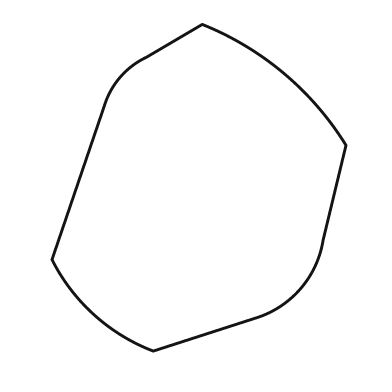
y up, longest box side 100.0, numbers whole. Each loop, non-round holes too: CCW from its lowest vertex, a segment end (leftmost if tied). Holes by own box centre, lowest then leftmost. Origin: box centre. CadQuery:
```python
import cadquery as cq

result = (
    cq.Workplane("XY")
    .moveTo(-14.0, -50.0)
    .lineTo(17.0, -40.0)
    .threePointArc((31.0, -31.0), (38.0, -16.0))
    .lineTo(45.0, 13.0)
    .threePointArc((26.0, 35.0), (1.0, 50.0))
    .lineTo(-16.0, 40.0)
    .threePointArc((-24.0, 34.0), (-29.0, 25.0))
    .lineTo(-45.0, -22.0)
    .threePointArc((-32.0, -39.0), (-14.0, -50.0))
    .close()
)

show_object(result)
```